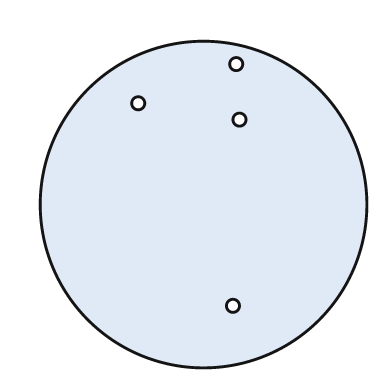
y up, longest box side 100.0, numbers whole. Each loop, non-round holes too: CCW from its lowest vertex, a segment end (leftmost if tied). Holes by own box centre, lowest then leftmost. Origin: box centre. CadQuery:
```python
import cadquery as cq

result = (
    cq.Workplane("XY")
    .moveTo(0.0, 0.0)
    .circle(50.0)
    .moveTo(9.0, -31.0)
    .circle(2.0)
    .moveTo(11.0, 26.0)
    .circle(2.0)
    .moveTo(-20.0, 31.0)
    .circle(2.0)
    .moveTo(10.0, 43.0)
    .circle(2.0)
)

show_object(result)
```